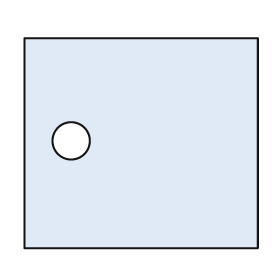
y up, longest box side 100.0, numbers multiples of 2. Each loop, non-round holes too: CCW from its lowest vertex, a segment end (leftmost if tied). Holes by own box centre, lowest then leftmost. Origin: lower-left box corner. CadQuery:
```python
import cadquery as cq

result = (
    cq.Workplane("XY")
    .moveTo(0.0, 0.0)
    .lineTo(100.0, 0.0)
    .lineTo(100.0, 90.0)
    .lineTo(0.0, 90.0)
    .close()
    .moveTo(20.0, 46.0)
    .circle(8.0)
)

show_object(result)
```